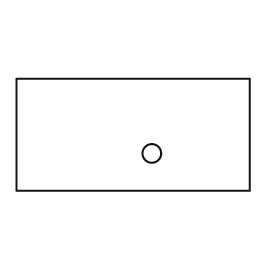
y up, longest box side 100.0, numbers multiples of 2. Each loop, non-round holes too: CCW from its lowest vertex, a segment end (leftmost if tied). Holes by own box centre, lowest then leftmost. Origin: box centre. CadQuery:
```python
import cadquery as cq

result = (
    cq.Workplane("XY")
    .moveTo(-50.0, -24.0)
    .lineTo(50.0, -24.0)
    .lineTo(50.0, 24.0)
    .lineTo(-50.0, 24.0)
    .close()
    .moveTo(8.0, -8.0)
    .circle(4.0)
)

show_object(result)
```